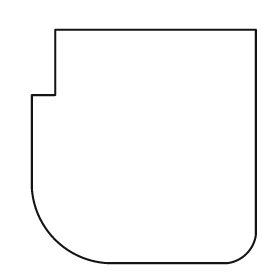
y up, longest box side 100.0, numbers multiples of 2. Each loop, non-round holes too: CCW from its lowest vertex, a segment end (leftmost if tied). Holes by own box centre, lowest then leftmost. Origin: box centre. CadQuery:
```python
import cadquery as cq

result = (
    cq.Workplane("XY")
    .moveTo(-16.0, -50.0)
    .lineTo(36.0, -50.0)
    .threePointArc((44.0, -46.0), (48.0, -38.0))
    .lineTo(48.0, 50.0)
    .lineTo(-38.0, 50.0)
    .lineTo(-38.0, 22.0)
    .lineTo(-48.0, 22.0)
    .lineTo(-48.0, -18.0)
    .threePointArc((-38.0, -40.0), (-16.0, -50.0))
    .close()
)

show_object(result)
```